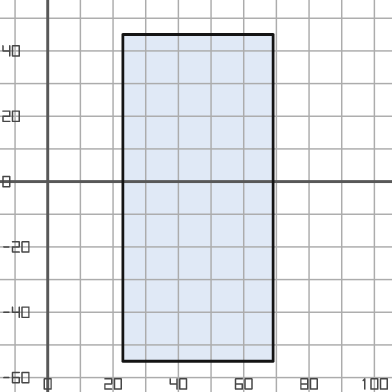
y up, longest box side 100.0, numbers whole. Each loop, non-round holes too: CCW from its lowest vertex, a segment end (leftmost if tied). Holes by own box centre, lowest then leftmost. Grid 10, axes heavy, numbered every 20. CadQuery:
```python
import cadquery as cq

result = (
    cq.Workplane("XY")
    .moveTo(23.0, -55.0)
    .lineTo(69.0, -55.0)
    .lineTo(69.0, 45.0)
    .lineTo(23.0, 45.0)
    .close()
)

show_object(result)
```